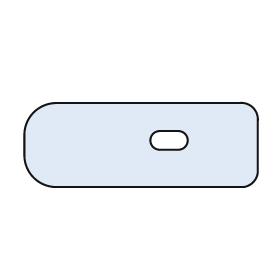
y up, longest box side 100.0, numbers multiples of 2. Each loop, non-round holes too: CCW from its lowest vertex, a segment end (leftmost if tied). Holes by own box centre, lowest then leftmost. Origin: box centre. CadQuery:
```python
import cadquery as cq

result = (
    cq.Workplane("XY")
    .moveTo(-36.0, -18.0)
    .lineTo(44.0, -18.0)
    .threePointArc((48.0, -16.0), (50.0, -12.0))
    .lineTo(50.0, 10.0)
    .threePointArc((48.0, 16.0), (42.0, 18.0))
    .lineTo(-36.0, 18.0)
    .threePointArc((-46.0, 14.0), (-50.0, 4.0))
    .lineTo(-50.0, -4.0)
    .threePointArc((-46.0, -14.0), (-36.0, -18.0))
    .close()
    .moveTo(8.0, -2.0)
    .lineTo(16.0, -2.0)
    .threePointArc((20.0, 2.0), (16.0, 6.0))
    .lineTo(8.0, 6.0)
    .threePointArc((4.0, 2.0), (8.0, -2.0))
    .close()
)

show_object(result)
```